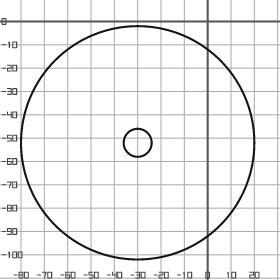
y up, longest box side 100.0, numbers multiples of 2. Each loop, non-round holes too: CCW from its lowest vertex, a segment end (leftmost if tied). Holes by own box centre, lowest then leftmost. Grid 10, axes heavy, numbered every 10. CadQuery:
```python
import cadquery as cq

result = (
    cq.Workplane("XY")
    .moveTo(-30.0, -52.0)
    .circle(50.0)
    .moveTo(-30.0, -52.0)
    .circle(6.0)
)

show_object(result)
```